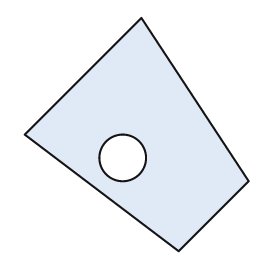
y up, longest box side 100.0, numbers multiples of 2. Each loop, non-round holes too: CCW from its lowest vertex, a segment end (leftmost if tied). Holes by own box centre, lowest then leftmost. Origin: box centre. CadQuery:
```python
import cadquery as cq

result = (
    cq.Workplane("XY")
    .moveTo(18.0, -50.0)
    .lineTo(48.0, -20.0)
    .lineTo(2.0, 50.0)
    .lineTo(-48.0, 0.0)
    .close()
    .moveTo(-6.0, -10.0)
    .circle(10.0)
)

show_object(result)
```